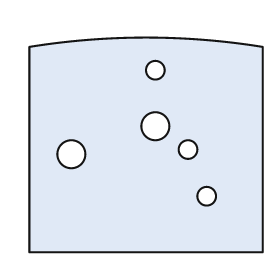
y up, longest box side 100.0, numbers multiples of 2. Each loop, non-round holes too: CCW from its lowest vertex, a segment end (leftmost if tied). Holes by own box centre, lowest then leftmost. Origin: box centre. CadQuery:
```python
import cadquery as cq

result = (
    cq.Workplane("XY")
    .moveTo(-50.0, -46.0)
    .lineTo(50.0, -46.0)
    .lineTo(50.0, 42.0)
    .threePointArc((0.0, 46.0), (-50.0, 42.0))
    .close()
    .moveTo(26.0, -22.0)
    .circle(4.0)
    .moveTo(-32.0, -4.0)
    .circle(6.0)
    .moveTo(18.0, -2.0)
    .circle(4.0)
    .moveTo(4.0, 8.0)
    .circle(6.0)
    .moveTo(4.0, 32.0)
    .circle(4.0)
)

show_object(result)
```